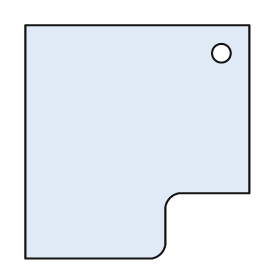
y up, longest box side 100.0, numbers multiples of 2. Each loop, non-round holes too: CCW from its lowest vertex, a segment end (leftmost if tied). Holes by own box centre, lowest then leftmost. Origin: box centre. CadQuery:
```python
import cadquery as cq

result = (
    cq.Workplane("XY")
    .moveTo(-48.0, -50.0)
    .lineTo(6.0, -50.0)
    .threePointArc((10.0, -48.0), (12.0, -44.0))
    .lineTo(12.0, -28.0)
    .threePointArc((14.0, -24.0), (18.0, -22.0))
    .lineTo(48.0, -22.0)
    .lineTo(48.0, 50.0)
    .lineTo(-48.0, 50.0)
    .close()
    .moveTo(36.0, 38.0)
    .circle(4.0)
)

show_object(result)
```